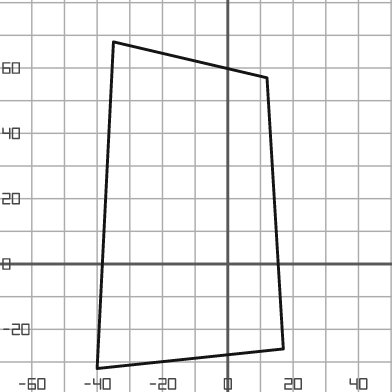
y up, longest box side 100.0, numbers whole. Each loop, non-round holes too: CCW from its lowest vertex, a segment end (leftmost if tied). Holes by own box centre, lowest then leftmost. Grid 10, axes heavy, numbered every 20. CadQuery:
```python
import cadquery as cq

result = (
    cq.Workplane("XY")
    .moveTo(-40.0, -32.0)
    .lineTo(17.0, -26.0)
    .lineTo(12.0, 57.0)
    .lineTo(-35.0, 68.0)
    .close()
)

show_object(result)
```